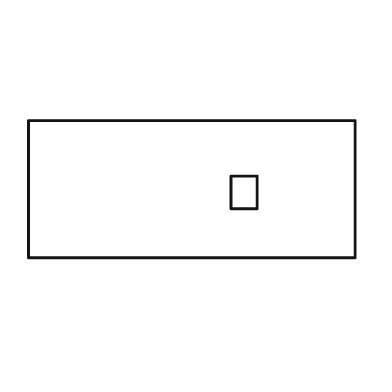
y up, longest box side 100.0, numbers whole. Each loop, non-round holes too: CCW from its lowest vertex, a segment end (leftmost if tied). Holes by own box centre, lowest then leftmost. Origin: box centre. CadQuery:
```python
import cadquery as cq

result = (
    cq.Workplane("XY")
    .moveTo(-50.0, -21.0)
    .lineTo(50.0, -21.0)
    .lineTo(50.0, 21.0)
    .lineTo(-50.0, 21.0)
    .close()
    .moveTo(12.0, -6.0)
    .lineTo(20.0, -6.0)
    .lineTo(20.0, 4.0)
    .lineTo(12.0, 4.0)
    .close()
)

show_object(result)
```